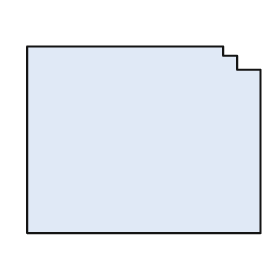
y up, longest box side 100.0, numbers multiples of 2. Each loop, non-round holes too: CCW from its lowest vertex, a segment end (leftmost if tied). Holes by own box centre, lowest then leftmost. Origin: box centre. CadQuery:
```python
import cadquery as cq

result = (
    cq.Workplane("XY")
    .moveTo(-50.0, -40.0)
    .lineTo(50.0, -40.0)
    .lineTo(50.0, 30.0)
    .lineTo(40.0, 30.0)
    .lineTo(40.0, 36.0)
    .lineTo(34.0, 36.0)
    .lineTo(34.0, 40.0)
    .lineTo(-50.0, 40.0)
    .close()
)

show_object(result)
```